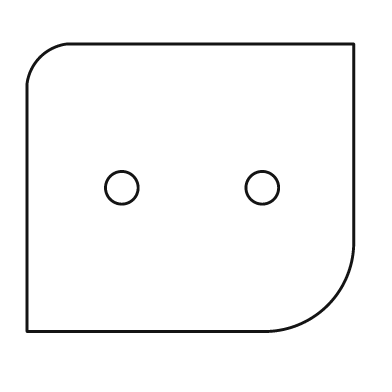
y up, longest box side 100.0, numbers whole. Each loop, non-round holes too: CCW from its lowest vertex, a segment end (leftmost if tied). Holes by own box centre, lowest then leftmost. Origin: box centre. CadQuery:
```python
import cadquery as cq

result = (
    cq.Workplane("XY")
    .moveTo(-50.0, -44.0)
    .lineTo(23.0, -44.0)
    .threePointArc((42.0, -36.0), (50.0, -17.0))
    .lineTo(50.0, 44.0)
    .lineTo(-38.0, 44.0)
    .threePointArc((-46.0, 40.0), (-50.0, 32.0))
    .close()
    .moveTo(-21.0, 0.0)
    .circle(5.0)
    .moveTo(22.0, 0.0)
    .circle(5.0)
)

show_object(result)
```